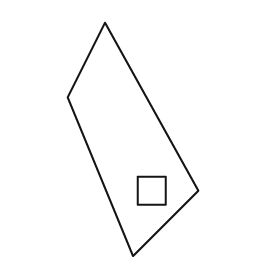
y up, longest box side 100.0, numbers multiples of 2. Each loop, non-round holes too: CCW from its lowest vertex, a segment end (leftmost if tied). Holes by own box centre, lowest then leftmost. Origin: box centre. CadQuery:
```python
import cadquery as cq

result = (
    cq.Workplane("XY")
    .moveTo(0.0, -50.0)
    .lineTo(28.0, -22.0)
    .lineTo(-12.0, 50.0)
    .lineTo(-28.0, 18.0)
    .close()
    .moveTo(2.0, -28.0)
    .lineTo(14.0, -28.0)
    .lineTo(14.0, -16.0)
    .lineTo(2.0, -16.0)
    .close()
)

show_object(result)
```